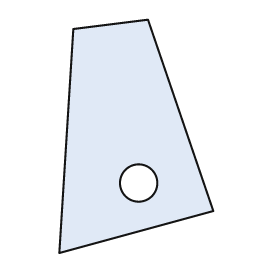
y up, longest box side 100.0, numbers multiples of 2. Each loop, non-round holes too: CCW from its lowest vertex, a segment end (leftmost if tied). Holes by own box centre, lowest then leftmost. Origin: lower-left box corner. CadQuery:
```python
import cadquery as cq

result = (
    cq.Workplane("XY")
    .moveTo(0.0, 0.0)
    .lineTo(66.0, 18.0)
    .lineTo(38.0, 100.0)
    .lineTo(6.0, 96.0)
    .close()
    .moveTo(34.0, 30.0)
    .circle(8.0)
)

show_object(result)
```